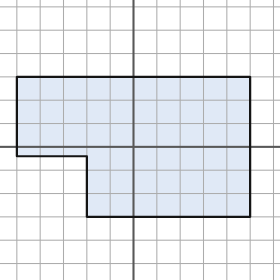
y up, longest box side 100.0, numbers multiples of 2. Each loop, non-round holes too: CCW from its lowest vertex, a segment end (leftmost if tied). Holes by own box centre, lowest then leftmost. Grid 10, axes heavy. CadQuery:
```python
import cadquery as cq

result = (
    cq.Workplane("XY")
    .moveTo(-20.0, -30.0)
    .lineTo(50.0, -30.0)
    .lineTo(50.0, 30.0)
    .lineTo(-50.0, 30.0)
    .lineTo(-50.0, -4.0)
    .lineTo(-20.0, -4.0)
    .close()
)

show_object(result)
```